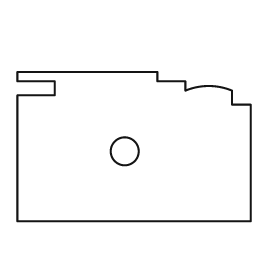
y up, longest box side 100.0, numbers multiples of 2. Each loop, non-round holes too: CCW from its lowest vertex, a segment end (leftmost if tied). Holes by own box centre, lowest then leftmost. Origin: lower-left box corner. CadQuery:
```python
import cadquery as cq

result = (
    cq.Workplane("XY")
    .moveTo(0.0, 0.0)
    .lineTo(100.0, 0.0)
    .lineTo(100.0, 50.0)
    .lineTo(92.0, 50.0)
    .lineTo(92.0, 56.0)
    .threePointArc((82.0, 58.0), (72.0, 56.0))
    .lineTo(72.0, 60.0)
    .lineTo(60.0, 60.0)
    .lineTo(60.0, 64.0)
    .lineTo(0.0, 64.0)
    .lineTo(0.0, 60.0)
    .lineTo(16.0, 60.0)
    .lineTo(16.0, 54.0)
    .lineTo(0.0, 54.0)
    .close()
    .moveTo(46.0, 30.0)
    .circle(6.0)
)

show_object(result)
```